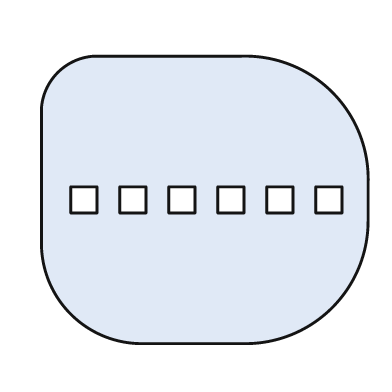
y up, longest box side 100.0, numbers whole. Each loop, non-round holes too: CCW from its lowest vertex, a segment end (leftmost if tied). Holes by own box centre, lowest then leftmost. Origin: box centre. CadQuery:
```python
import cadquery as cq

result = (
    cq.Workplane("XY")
    .moveTo(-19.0, -44.0)
    .lineTo(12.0, -44.0)
    .threePointArc((39.0, -33.0), (50.0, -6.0))
    .lineTo(50.0, 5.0)
    .threePointArc((39.0, 33.0), (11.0, 44.0))
    .lineTo(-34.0, 44.0)
    .threePointArc((-45.0, 39.0), (-50.0, 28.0))
    .lineTo(-50.0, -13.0)
    .threePointArc((-41.0, -35.0), (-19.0, -44.0))
    .close()
    .moveTo(-41.0, -4.0)
    .lineTo(-33.0, -4.0)
    .lineTo(-33.0, 4.0)
    .lineTo(-41.0, 4.0)
    .close()
    .moveTo(-26.0, -4.0)
    .lineTo(-18.0, -4.0)
    .lineTo(-18.0, 4.0)
    .lineTo(-26.0, 4.0)
    .close()
    .moveTo(-11.0, -4.0)
    .lineTo(-3.0, -4.0)
    .lineTo(-3.0, 4.0)
    .lineTo(-11.0, 4.0)
    .close()
    .moveTo(4.0, -4.0)
    .lineTo(12.0, -4.0)
    .lineTo(12.0, 4.0)
    .lineTo(4.0, 4.0)
    .close()
    .moveTo(19.0, -4.0)
    .lineTo(27.0, -4.0)
    .lineTo(27.0, 4.0)
    .lineTo(19.0, 4.0)
    .close()
    .moveTo(34.0, -4.0)
    .lineTo(42.0, -4.0)
    .lineTo(42.0, 4.0)
    .lineTo(34.0, 4.0)
    .close()
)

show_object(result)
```